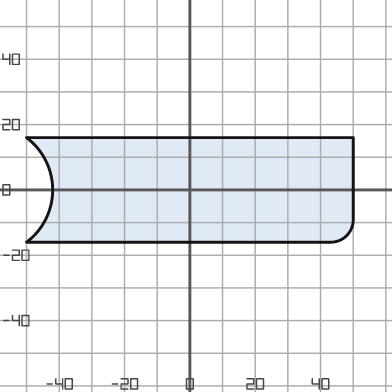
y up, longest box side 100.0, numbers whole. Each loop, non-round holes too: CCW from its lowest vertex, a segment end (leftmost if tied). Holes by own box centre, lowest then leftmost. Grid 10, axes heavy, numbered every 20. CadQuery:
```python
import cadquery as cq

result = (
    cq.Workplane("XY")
    .moveTo(-50.0, -16.0)
    .lineTo(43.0, -16.0)
    .threePointArc((48.0, -14.0), (50.0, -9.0))
    .lineTo(50.0, 16.0)
    .lineTo(-50.0, 16.0)
    .threePointArc((-42.0, 0.0), (-50.0, -16.0))
    .close()
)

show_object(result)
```